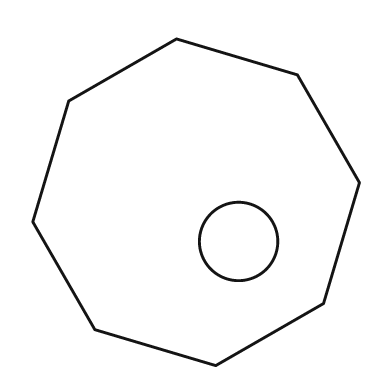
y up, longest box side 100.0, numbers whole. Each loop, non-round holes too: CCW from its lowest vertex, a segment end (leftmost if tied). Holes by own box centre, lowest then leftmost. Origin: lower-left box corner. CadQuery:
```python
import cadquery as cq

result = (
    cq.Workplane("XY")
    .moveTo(56.0, 0.0)
    .lineTo(89.0, 19.0)
    .lineTo(100.0, 56.0)
    .lineTo(81.0, 89.0)
    .lineTo(44.0, 100.0)
    .lineTo(11.0, 81.0)
    .lineTo(0.0, 44.0)
    .lineTo(19.0, 11.0)
    .close()
    .moveTo(63.0, 38.0)
    .circle(12.0)
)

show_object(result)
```